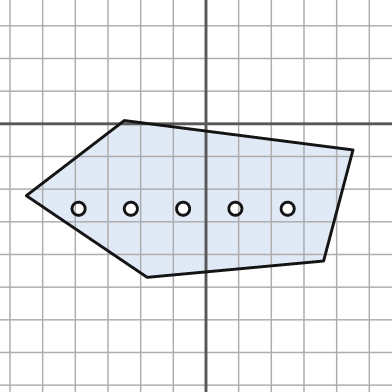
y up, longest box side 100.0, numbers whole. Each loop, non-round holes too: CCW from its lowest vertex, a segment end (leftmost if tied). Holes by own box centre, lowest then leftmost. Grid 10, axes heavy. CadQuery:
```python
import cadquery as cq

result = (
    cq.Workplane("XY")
    .moveTo(-18.0, -47.0)
    .lineTo(36.0, -42.0)
    .lineTo(45.0, -8.0)
    .lineTo(-25.0, 1.0)
    .lineTo(-55.0, -22.0)
    .close()
    .moveTo(-39.0, -26.0)
    .circle(2.0)
    .moveTo(-23.0, -26.0)
    .circle(2.0)
    .moveTo(-7.0, -26.0)
    .circle(2.0)
    .moveTo(9.0, -26.0)
    .circle(2.0)
    .moveTo(25.0, -26.0)
    .circle(2.0)
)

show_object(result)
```